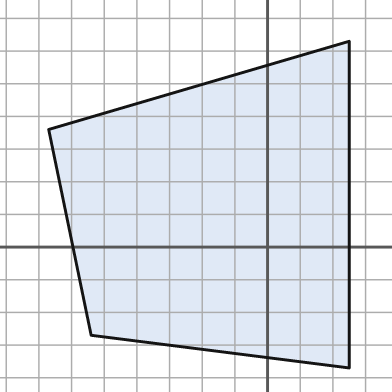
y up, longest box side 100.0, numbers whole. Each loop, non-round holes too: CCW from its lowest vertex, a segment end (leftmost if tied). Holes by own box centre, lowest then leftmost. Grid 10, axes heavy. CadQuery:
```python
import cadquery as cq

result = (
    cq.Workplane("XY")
    .moveTo(25.0, -37.0)
    .lineTo(25.0, 63.0)
    .lineTo(-67.0, 36.0)
    .lineTo(-54.0, -27.0)
    .close()
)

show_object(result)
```